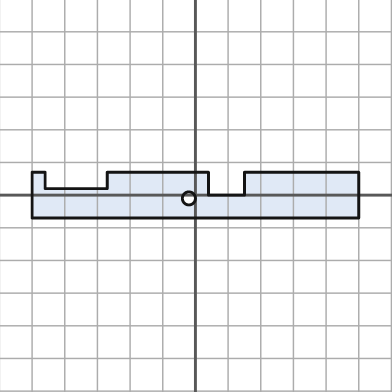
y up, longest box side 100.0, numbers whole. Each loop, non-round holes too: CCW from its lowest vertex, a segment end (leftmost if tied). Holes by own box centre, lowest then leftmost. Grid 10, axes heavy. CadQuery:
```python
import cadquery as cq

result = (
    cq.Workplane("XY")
    .moveTo(-50.0, -7.0)
    .lineTo(50.0, -7.0)
    .lineTo(50.0, 7.0)
    .lineTo(15.0, 7.0)
    .lineTo(15.0, 0.0)
    .lineTo(4.0, 0.0)
    .lineTo(4.0, 7.0)
    .lineTo(-27.0, 7.0)
    .lineTo(-27.0, 2.0)
    .lineTo(-46.0, 2.0)
    .lineTo(-46.0, 7.0)
    .lineTo(-50.0, 7.0)
    .close()
    .moveTo(-2.0, -1.0)
    .circle(2.0)
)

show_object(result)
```